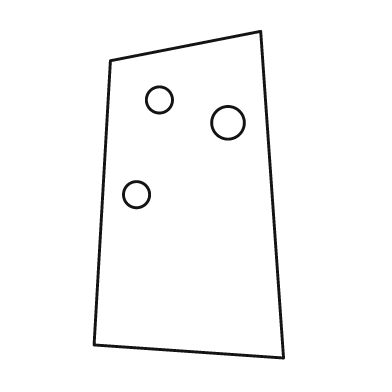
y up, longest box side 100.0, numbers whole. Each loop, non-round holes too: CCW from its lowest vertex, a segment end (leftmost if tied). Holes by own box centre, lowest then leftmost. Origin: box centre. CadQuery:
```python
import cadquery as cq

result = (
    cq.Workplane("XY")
    .moveTo(29.0, -50.0)
    .lineTo(22.0, 50.0)
    .lineTo(-24.0, 41.0)
    .lineTo(-29.0, -46.0)
    .close()
    .moveTo(-16.0, 0.0)
    .circle(4.0)
    .moveTo(12.0, 22.0)
    .circle(5.0)
    .moveTo(-9.0, 29.0)
    .circle(4.0)
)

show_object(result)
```